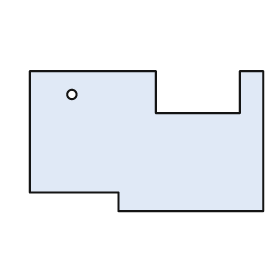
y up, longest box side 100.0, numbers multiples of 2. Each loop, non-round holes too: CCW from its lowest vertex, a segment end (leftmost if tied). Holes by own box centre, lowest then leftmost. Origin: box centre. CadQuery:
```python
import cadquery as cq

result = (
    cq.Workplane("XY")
    .moveTo(-12.0, -30.0)
    .lineTo(50.0, -30.0)
    .lineTo(50.0, 30.0)
    .lineTo(40.0, 30.0)
    .lineTo(40.0, 12.0)
    .lineTo(4.0, 12.0)
    .lineTo(4.0, 30.0)
    .lineTo(-50.0, 30.0)
    .lineTo(-50.0, -22.0)
    .lineTo(-12.0, -22.0)
    .close()
    .moveTo(-32.0, 20.0)
    .circle(2.0)
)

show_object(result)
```